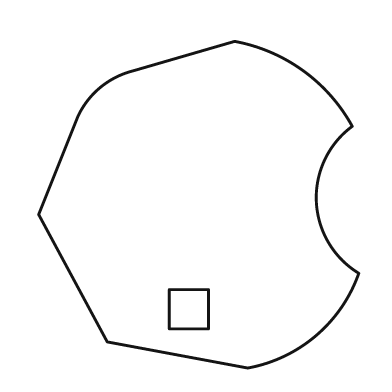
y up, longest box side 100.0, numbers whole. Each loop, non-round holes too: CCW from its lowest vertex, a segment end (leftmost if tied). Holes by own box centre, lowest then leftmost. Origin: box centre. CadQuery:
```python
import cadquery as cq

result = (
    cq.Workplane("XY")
    .moveTo(15.0, -50.0)
    .threePointArc((36.0, -40.0), (49.0, -21.0))
    .threePointArc((36.0, 1.0), (47.0, 24.0))
    .threePointArc((32.0, 41.0), (11.0, 50.0))
    .lineTo(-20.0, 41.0)
    .threePointArc((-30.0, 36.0), (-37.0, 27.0))
    .lineTo(-49.0, -3.0)
    .lineTo(-28.0, -42.0)
    .close()
    .moveTo(-9.0, -38.0)
    .lineTo(3.0, -38.0)
    .lineTo(3.0, -26.0)
    .lineTo(-9.0, -26.0)
    .close()
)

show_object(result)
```